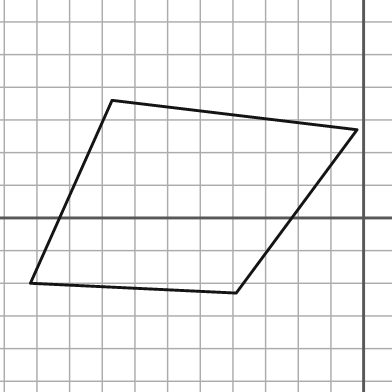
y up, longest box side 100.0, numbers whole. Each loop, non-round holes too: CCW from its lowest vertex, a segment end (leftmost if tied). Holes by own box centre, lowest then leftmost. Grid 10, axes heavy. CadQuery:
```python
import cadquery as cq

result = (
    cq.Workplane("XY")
    .moveTo(-39.0, -23.0)
    .lineTo(-2.0, 27.0)
    .lineTo(-77.0, 36.0)
    .lineTo(-102.0, -20.0)
    .close()
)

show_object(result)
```